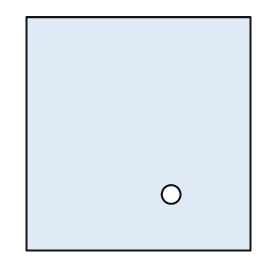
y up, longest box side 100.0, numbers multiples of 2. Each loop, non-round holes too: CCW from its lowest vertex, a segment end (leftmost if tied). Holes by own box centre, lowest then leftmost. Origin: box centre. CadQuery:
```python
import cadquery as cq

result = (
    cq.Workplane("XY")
    .moveTo(-48.0, -50.0)
    .lineTo(48.0, -50.0)
    .lineTo(48.0, 50.0)
    .lineTo(-48.0, 50.0)
    .close()
    .moveTo(14.0, -26.0)
    .circle(4.0)
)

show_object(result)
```